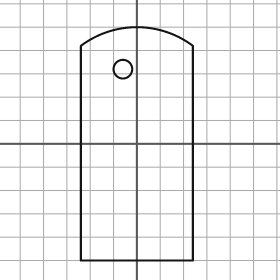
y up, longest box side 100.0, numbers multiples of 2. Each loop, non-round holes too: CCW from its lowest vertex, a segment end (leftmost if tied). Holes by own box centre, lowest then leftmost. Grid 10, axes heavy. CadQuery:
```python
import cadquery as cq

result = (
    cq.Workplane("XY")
    .moveTo(-24.0, -50.0)
    .lineTo(24.0, -50.0)
    .lineTo(24.0, 42.0)
    .threePointArc((0.0, 50.0), (-24.0, 42.0))
    .close()
    .moveTo(-6.0, 32.0)
    .circle(4.0)
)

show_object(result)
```